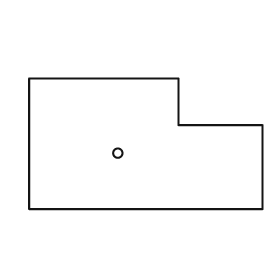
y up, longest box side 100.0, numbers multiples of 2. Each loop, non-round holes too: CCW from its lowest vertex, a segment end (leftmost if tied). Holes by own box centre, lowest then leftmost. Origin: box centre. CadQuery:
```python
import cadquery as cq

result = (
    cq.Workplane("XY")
    .moveTo(-50.0, -28.0)
    .lineTo(50.0, -28.0)
    .lineTo(50.0, 8.0)
    .lineTo(14.0, 8.0)
    .lineTo(14.0, 28.0)
    .lineTo(-50.0, 28.0)
    .close()
    .moveTo(-12.0, -4.0)
    .circle(2.0)
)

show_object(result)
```